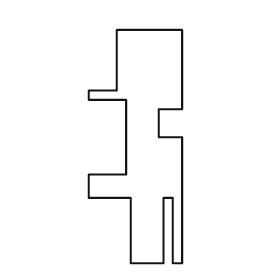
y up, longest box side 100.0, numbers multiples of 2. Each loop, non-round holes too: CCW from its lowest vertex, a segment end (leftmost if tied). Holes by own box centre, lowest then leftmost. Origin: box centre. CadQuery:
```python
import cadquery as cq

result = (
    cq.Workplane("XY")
    .moveTo(-2.0, -50.0)
    .lineTo(12.0, -50.0)
    .lineTo(12.0, -22.0)
    .lineTo(16.0, -22.0)
    .lineTo(16.0, -50.0)
    .lineTo(20.0, -50.0)
    .lineTo(20.0, 4.0)
    .lineTo(10.0, 4.0)
    .lineTo(10.0, 16.0)
    .lineTo(20.0, 16.0)
    .lineTo(20.0, 50.0)
    .lineTo(-8.0, 50.0)
    .lineTo(-8.0, 24.0)
    .lineTo(-20.0, 24.0)
    .lineTo(-20.0, 20.0)
    .lineTo(-4.0, 20.0)
    .lineTo(-4.0, -12.0)
    .lineTo(-20.0, -12.0)
    .lineTo(-20.0, -22.0)
    .lineTo(-2.0, -22.0)
    .close()
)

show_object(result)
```